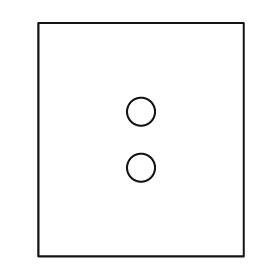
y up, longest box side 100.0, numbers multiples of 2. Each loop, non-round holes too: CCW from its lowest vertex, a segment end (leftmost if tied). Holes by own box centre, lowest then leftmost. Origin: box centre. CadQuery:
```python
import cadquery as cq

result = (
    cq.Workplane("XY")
    .moveTo(-44.0, -50.0)
    .lineTo(44.0, -50.0)
    .lineTo(44.0, 50.0)
    .lineTo(-44.0, 50.0)
    .close()
    .moveTo(0.0, -12.0)
    .circle(6.0)
    .moveTo(0.0, 12.0)
    .circle(6.0)
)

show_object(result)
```